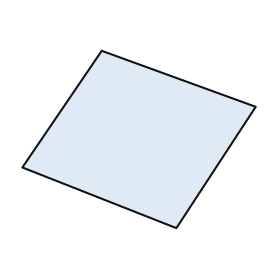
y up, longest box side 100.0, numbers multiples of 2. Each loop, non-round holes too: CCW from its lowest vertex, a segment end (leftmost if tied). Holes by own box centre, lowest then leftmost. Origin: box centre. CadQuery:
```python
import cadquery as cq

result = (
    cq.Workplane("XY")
    .moveTo(16.0, -38.0)
    .lineTo(50.0, 14.0)
    .lineTo(-16.0, 38.0)
    .lineTo(-50.0, -12.0)
    .close()
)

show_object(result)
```